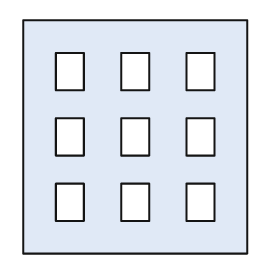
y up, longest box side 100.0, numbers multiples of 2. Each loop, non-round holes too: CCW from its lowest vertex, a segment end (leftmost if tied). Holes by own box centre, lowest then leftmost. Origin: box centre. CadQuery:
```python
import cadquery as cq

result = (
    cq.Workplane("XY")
    .moveTo(-48.0, -50.0)
    .lineTo(48.0, -50.0)
    .lineTo(48.0, 50.0)
    .lineTo(-48.0, 50.0)
    .close()
    .moveTo(-34.0, -36.0)
    .lineTo(-22.0, -36.0)
    .lineTo(-22.0, -20.0)
    .lineTo(-34.0, -20.0)
    .close()
    .moveTo(-6.0, -36.0)
    .lineTo(6.0, -36.0)
    .lineTo(6.0, -20.0)
    .lineTo(-6.0, -20.0)
    .close()
    .moveTo(22.0, -36.0)
    .lineTo(34.0, -36.0)
    .lineTo(34.0, -20.0)
    .lineTo(22.0, -20.0)
    .close()
    .moveTo(-34.0, -8.0)
    .lineTo(-22.0, -8.0)
    .lineTo(-22.0, 8.0)
    .lineTo(-34.0, 8.0)
    .close()
    .moveTo(-6.0, -8.0)
    .lineTo(6.0, -8.0)
    .lineTo(6.0, 8.0)
    .lineTo(-6.0, 8.0)
    .close()
    .moveTo(22.0, -8.0)
    .lineTo(34.0, -8.0)
    .lineTo(34.0, 8.0)
    .lineTo(22.0, 8.0)
    .close()
    .moveTo(-34.0, 20.0)
    .lineTo(-22.0, 20.0)
    .lineTo(-22.0, 36.0)
    .lineTo(-34.0, 36.0)
    .close()
    .moveTo(-6.0, 20.0)
    .lineTo(6.0, 20.0)
    .lineTo(6.0, 36.0)
    .lineTo(-6.0, 36.0)
    .close()
    .moveTo(22.0, 20.0)
    .lineTo(34.0, 20.0)
    .lineTo(34.0, 36.0)
    .lineTo(22.0, 36.0)
    .close()
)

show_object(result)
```